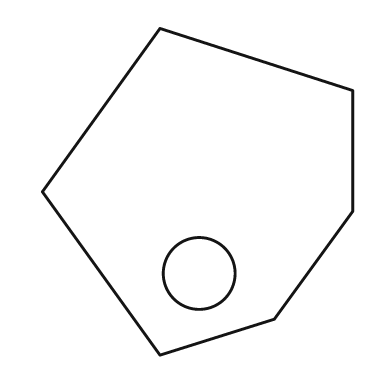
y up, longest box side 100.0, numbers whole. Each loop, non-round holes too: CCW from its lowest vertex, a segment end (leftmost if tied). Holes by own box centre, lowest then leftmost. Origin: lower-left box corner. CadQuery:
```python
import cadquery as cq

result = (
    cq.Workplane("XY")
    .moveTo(36.0, 0.0)
    .lineTo(71.0, 11.0)
    .lineTo(95.0, 44.0)
    .lineTo(95.0, 81.0)
    .lineTo(36.0, 100.0)
    .lineTo(0.0, 50.0)
    .close()
    .moveTo(48.0, 25.0)
    .circle(11.0)
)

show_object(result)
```